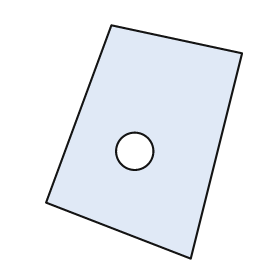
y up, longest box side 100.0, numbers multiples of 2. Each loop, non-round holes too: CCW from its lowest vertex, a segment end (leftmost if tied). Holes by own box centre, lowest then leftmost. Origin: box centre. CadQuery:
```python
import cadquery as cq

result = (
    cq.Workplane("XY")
    .moveTo(20.0, -50.0)
    .lineTo(42.0, 38.0)
    .lineTo(-14.0, 50.0)
    .lineTo(-42.0, -26.0)
    .close()
    .moveTo(-4.0, -4.0)
    .circle(8.0)
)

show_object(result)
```